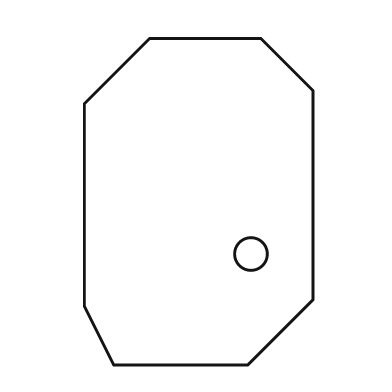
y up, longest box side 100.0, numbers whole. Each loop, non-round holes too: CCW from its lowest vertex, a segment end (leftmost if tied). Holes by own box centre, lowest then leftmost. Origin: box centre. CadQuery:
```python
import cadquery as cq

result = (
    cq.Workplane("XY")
    .moveTo(-26.0, -50.0)
    .lineTo(15.0, -50.0)
    .lineTo(35.0, -30.0)
    .lineTo(35.0, 34.0)
    .lineTo(19.0, 50.0)
    .lineTo(-15.0, 50.0)
    .lineTo(-35.0, 30.0)
    .lineTo(-35.0, -32.0)
    .close()
    .moveTo(16.0, -16.0)
    .circle(5.0)
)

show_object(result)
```